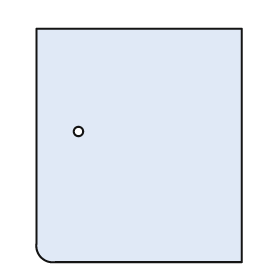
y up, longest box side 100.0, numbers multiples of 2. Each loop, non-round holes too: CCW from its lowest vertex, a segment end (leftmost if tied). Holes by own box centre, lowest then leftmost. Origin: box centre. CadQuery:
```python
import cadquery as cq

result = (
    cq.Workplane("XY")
    .moveTo(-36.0, -50.0)
    .lineTo(44.0, -50.0)
    .lineTo(44.0, 50.0)
    .lineTo(-44.0, 50.0)
    .lineTo(-44.0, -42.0)
    .threePointArc((-42.0, -48.0), (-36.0, -50.0))
    .close()
    .moveTo(-26.0, 6.0)
    .circle(2.0)
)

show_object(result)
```